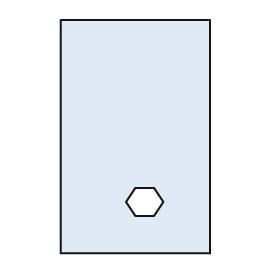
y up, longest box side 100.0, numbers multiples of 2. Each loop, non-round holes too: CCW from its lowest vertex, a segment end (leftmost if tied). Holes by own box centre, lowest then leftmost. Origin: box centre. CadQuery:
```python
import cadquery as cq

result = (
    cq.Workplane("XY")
    .moveTo(-32.0, -50.0)
    .lineTo(32.0, -50.0)
    .lineTo(32.0, 50.0)
    .lineTo(-32.0, 50.0)
    .close()
    .moveTo(0.0, -34.0)
    .lineTo(8.0, -34.0)
    .lineTo(12.0, -28.0)
    .lineTo(8.0, -22.0)
    .lineTo(0.0, -22.0)
    .lineTo(-4.0, -28.0)
    .close()
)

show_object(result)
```